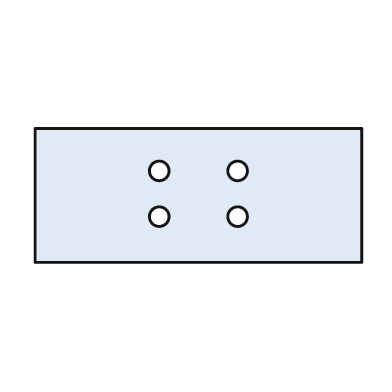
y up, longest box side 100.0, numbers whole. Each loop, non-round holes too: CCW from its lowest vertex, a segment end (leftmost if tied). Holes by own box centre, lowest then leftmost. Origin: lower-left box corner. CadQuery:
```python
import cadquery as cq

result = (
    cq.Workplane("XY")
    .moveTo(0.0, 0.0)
    .lineTo(100.0, 0.0)
    .lineTo(100.0, 41.0)
    .lineTo(0.0, 41.0)
    .close()
    .moveTo(38.0, 14.0)
    .circle(3.0)
    .moveTo(62.0, 14.0)
    .circle(3.0)
    .moveTo(38.0, 28.0)
    .circle(3.0)
    .moveTo(62.0, 28.0)
    .circle(3.0)
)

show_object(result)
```